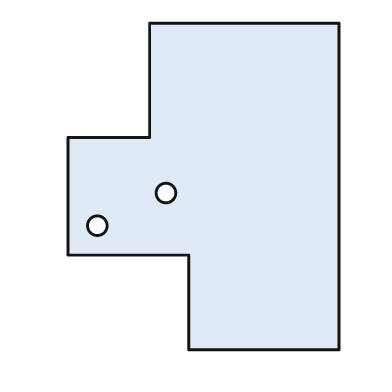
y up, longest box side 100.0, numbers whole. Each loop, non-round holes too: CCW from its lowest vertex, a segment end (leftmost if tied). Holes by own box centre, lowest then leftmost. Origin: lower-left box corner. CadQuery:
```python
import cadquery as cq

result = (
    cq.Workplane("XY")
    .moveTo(37.0, 0.0)
    .lineTo(83.0, 0.0)
    .lineTo(83.0, 100.0)
    .lineTo(25.0, 100.0)
    .lineTo(25.0, 65.0)
    .lineTo(0.0, 65.0)
    .lineTo(0.0, 29.0)
    .lineTo(37.0, 29.0)
    .close()
    .moveTo(9.0, 38.0)
    .circle(3.0)
    .moveTo(30.0, 48.0)
    .circle(3.0)
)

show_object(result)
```